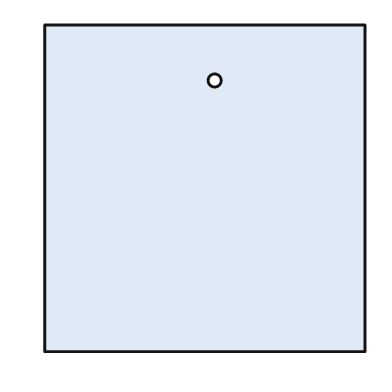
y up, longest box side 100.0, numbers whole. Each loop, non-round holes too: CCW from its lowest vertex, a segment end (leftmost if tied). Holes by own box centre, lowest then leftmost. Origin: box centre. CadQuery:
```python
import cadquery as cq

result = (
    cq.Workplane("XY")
    .moveTo(-49.0, -50.0)
    .lineTo(49.0, -50.0)
    .lineTo(49.0, 50.0)
    .lineTo(-49.0, 50.0)
    .close()
    .moveTo(3.0, 33.0)
    .circle(2.0)
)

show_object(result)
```